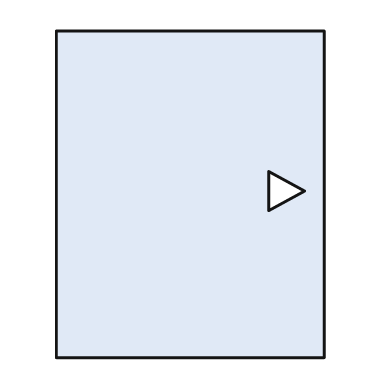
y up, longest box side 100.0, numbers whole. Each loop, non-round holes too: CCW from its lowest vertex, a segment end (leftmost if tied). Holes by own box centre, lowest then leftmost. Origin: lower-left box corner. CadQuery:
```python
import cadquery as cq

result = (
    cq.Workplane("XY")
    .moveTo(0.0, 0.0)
    .lineTo(82.0, 0.0)
    .lineTo(82.0, 100.0)
    .lineTo(0.0, 100.0)
    .close()
    .moveTo(65.0, 45.0)
    .lineTo(76.0, 51.0)
    .lineTo(65.0, 57.0)
    .close()
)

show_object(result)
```